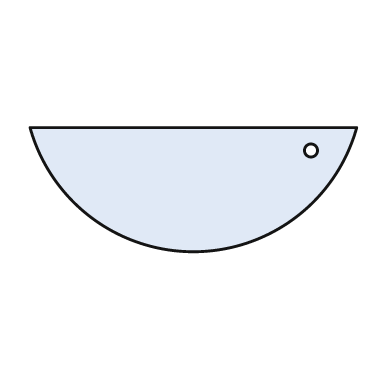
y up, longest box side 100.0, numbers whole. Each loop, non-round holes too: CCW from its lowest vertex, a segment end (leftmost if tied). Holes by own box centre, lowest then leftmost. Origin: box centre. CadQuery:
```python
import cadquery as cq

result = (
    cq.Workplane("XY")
    .moveTo(-50.0, 19.0)
    .threePointArc((0.0, -19.0), (50.0, 19.0))
    .close()
    .moveTo(36.0, 12.0)
    .circle(2.0)
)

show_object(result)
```